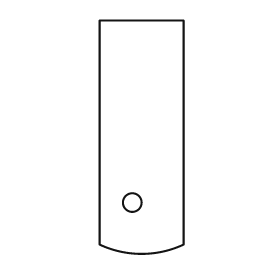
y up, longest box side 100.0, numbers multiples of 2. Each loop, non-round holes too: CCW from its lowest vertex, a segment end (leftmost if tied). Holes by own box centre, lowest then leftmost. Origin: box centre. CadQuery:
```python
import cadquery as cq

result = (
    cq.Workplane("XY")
    .moveTo(-18.0, -46.0)
    .threePointArc((0.0, -50.0), (18.0, -46.0))
    .lineTo(18.0, 50.0)
    .lineTo(-18.0, 50.0)
    .close()
    .moveTo(-4.0, -28.0)
    .circle(4.0)
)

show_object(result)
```